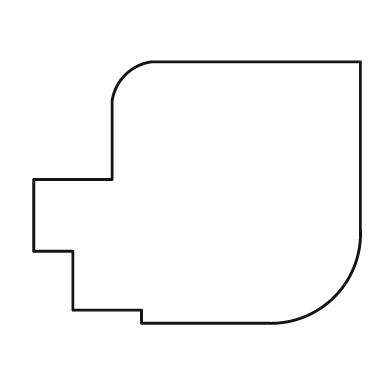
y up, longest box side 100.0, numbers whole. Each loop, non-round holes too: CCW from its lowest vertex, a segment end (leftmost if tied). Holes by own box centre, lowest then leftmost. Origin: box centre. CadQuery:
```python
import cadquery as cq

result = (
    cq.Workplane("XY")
    .moveTo(-17.0, -40.0)
    .lineTo(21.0, -40.0)
    .threePointArc((42.0, -32.0), (50.0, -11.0))
    .lineTo(50.0, 40.0)
    .lineTo(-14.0, 40.0)
    .threePointArc((-22.0, 36.0), (-26.0, 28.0))
    .lineTo(-26.0, 4.0)
    .lineTo(-50.0, 4.0)
    .lineTo(-50.0, -18.0)
    .lineTo(-38.0, -18.0)
    .lineTo(-38.0, -36.0)
    .lineTo(-17.0, -36.0)
    .close()
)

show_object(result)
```